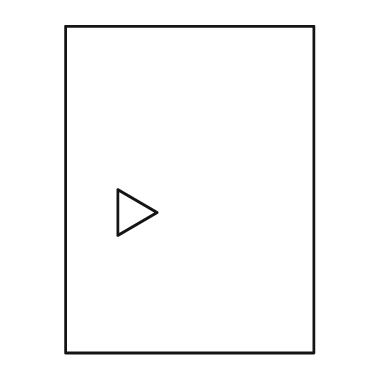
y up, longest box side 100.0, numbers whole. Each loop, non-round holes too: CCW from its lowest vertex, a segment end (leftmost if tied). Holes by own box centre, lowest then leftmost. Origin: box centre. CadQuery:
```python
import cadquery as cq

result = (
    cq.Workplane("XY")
    .moveTo(-38.0, -50.0)
    .lineTo(38.0, -50.0)
    .lineTo(38.0, 50.0)
    .lineTo(-38.0, 50.0)
    .close()
    .moveTo(-22.0, -14.0)
    .lineTo(-10.0, -7.0)
    .lineTo(-22.0, 0.0)
    .close()
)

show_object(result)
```